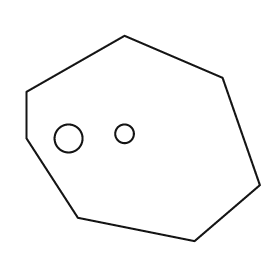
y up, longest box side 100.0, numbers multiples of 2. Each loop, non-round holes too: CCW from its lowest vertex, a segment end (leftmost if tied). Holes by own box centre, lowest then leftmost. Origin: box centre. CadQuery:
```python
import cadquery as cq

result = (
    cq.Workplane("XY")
    .moveTo(22.0, -44.0)
    .lineTo(50.0, -20.0)
    .lineTo(34.0, 26.0)
    .lineTo(-8.0, 44.0)
    .lineTo(-50.0, 20.0)
    .lineTo(-50.0, 0.0)
    .lineTo(-28.0, -34.0)
    .close()
    .moveTo(-32.0, 0.0)
    .circle(6.0)
    .moveTo(-8.0, 2.0)
    .circle(4.0)
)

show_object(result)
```